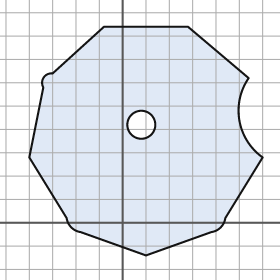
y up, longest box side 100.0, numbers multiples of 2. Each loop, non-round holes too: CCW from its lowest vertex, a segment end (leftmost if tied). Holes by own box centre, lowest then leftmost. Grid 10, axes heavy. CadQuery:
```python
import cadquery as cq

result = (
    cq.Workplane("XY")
    .moveTo(10.0, -14.0)
    .lineTo(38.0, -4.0)
    .threePointArc((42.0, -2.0), (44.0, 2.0))
    .lineTo(60.0, 28.0)
    .threePointArc((50.0, 44.0), (54.0, 62.0))
    .lineTo(28.0, 84.0)
    .lineTo(-8.0, 84.0)
    .lineTo(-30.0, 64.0)
    .threePointArc((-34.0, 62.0), (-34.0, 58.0))
    .lineTo(-40.0, 28.0)
    .lineTo(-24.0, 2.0)
    .threePointArc((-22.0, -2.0), (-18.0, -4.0))
    .close()
    .moveTo(8.0, 42.0)
    .circle(6.0)
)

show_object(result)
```